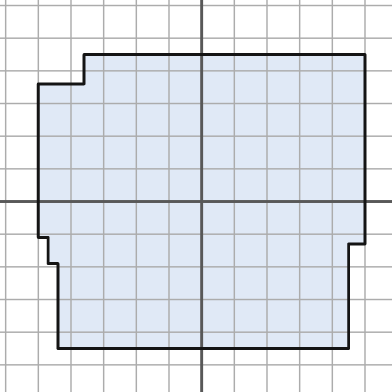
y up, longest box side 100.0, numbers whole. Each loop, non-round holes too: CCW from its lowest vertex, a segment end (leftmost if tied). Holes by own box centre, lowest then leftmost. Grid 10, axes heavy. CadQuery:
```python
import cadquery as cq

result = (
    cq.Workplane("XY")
    .moveTo(-44.0, -45.0)
    .lineTo(45.0, -45.0)
    .lineTo(45.0, -13.0)
    .lineTo(50.0, -13.0)
    .lineTo(50.0, 45.0)
    .lineTo(-36.0, 45.0)
    .lineTo(-36.0, 36.0)
    .lineTo(-50.0, 36.0)
    .lineTo(-50.0, -11.0)
    .lineTo(-47.0, -11.0)
    .lineTo(-47.0, -19.0)
    .lineTo(-44.0, -19.0)
    .close()
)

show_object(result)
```